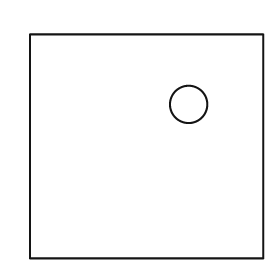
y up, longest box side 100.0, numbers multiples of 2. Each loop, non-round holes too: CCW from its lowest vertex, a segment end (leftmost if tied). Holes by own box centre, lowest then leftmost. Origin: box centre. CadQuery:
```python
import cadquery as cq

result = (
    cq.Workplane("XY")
    .moveTo(-50.0, -48.0)
    .lineTo(50.0, -48.0)
    .lineTo(50.0, 48.0)
    .lineTo(-50.0, 48.0)
    .close()
    .moveTo(18.0, 18.0)
    .circle(8.0)
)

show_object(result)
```